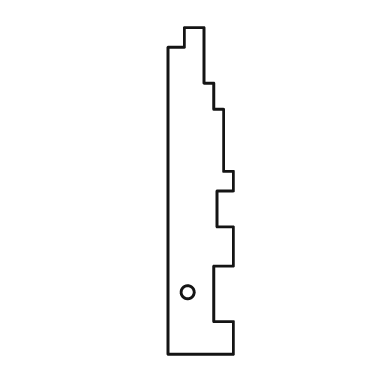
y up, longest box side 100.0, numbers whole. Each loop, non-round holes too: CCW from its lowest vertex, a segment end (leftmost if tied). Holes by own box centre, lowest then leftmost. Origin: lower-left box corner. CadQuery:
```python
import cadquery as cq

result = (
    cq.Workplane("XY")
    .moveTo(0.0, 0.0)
    .lineTo(20.0, 0.0)
    .lineTo(20.0, 10.0)
    .lineTo(14.0, 10.0)
    .lineTo(14.0, 27.0)
    .lineTo(20.0, 27.0)
    .lineTo(20.0, 39.0)
    .lineTo(15.0, 39.0)
    .lineTo(15.0, 50.0)
    .lineTo(20.0, 50.0)
    .lineTo(20.0, 56.0)
    .lineTo(17.0, 56.0)
    .lineTo(17.0, 75.0)
    .lineTo(14.0, 75.0)
    .lineTo(14.0, 83.0)
    .lineTo(11.0, 83.0)
    .lineTo(11.0, 100.0)
    .lineTo(5.0, 100.0)
    .lineTo(5.0, 94.0)
    .lineTo(0.0, 94.0)
    .close()
    .moveTo(6.0, 19.0)
    .circle(2.0)
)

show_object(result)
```